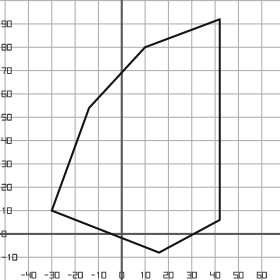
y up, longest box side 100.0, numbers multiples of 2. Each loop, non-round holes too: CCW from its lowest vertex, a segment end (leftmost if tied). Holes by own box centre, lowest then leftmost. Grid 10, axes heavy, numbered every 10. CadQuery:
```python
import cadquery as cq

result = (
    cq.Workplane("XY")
    .moveTo(16.0, -8.0)
    .lineTo(42.0, 6.0)
    .lineTo(42.0, 92.0)
    .lineTo(10.0, 80.0)
    .lineTo(-14.0, 54.0)
    .lineTo(-30.0, 10.0)
    .close()
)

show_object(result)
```